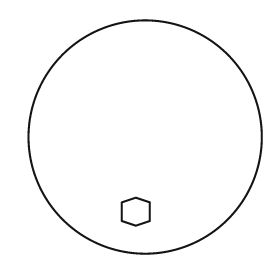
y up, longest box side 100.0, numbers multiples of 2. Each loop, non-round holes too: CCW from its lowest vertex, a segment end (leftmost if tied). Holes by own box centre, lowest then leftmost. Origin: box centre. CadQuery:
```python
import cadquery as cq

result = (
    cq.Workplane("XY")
    .moveTo(0.0, 0.0)
    .circle(50.0)
    .moveTo(-4.0, -38.0)
    .lineTo(2.0, -36.0)
    .lineTo(2.0, -28.0)
    .lineTo(-4.0, -26.0)
    .lineTo(-10.0, -28.0)
    .lineTo(-10.0, -36.0)
    .close()
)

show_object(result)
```